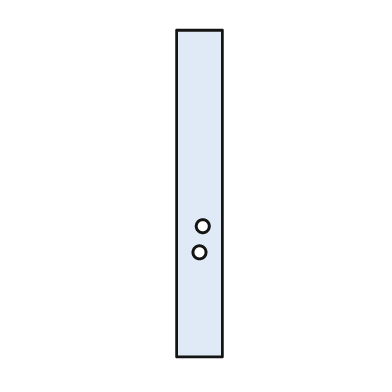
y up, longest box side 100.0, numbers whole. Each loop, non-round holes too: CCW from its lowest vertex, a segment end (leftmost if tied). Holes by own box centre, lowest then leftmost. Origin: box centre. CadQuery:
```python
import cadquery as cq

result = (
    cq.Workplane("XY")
    .moveTo(-7.0, -50.0)
    .lineTo(7.0, -50.0)
    .lineTo(7.0, 50.0)
    .lineTo(-7.0, 50.0)
    .close()
    .moveTo(0.0, -18.0)
    .circle(2.0)
    .moveTo(1.0, -10.0)
    .circle(2.0)
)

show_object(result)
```